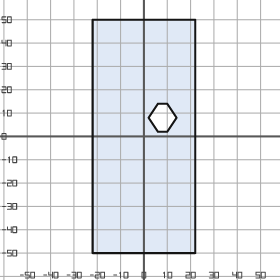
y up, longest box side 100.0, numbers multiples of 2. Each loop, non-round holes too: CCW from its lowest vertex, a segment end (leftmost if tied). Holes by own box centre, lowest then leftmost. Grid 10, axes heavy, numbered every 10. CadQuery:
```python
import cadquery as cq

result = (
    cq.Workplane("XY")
    .moveTo(-22.0, -50.0)
    .lineTo(22.0, -50.0)
    .lineTo(22.0, 50.0)
    .lineTo(-22.0, 50.0)
    .close()
    .moveTo(6.0, 2.0)
    .lineTo(10.0, 2.0)
    .lineTo(14.0, 8.0)
    .lineTo(10.0, 14.0)
    .lineTo(6.0, 14.0)
    .lineTo(2.0, 8.0)
    .close()
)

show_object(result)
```